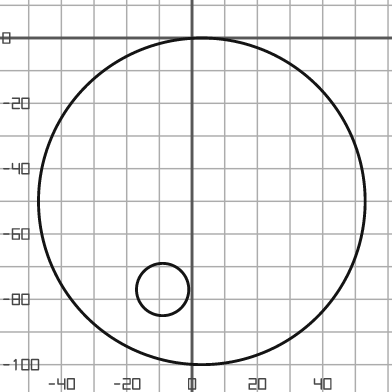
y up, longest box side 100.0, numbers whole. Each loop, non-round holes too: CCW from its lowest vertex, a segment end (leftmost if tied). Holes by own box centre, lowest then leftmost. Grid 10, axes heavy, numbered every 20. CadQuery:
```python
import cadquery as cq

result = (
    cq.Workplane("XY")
    .moveTo(3.0, -50.0)
    .circle(50.0)
    .moveTo(-9.0, -77.0)
    .circle(8.0)
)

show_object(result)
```